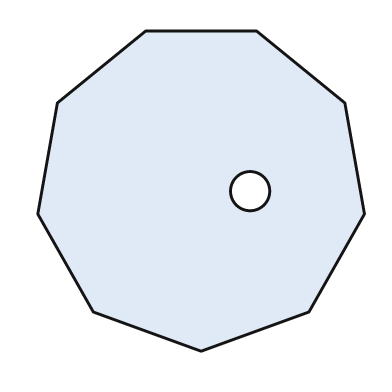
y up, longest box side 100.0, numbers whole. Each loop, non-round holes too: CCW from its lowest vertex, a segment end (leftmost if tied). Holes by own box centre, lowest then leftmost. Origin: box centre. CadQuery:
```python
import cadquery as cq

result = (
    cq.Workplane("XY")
    .moveTo(0.0, -49.0)
    .lineTo(33.0, -37.0)
    .lineTo(50.0, -7.0)
    .lineTo(44.0, 27.0)
    .lineTo(17.0, 49.0)
    .lineTo(-17.0, 49.0)
    .lineTo(-44.0, 27.0)
    .lineTo(-50.0, -7.0)
    .lineTo(-33.0, -37.0)
    .close()
    .moveTo(15.0, 0.0)
    .circle(6.0)
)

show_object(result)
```